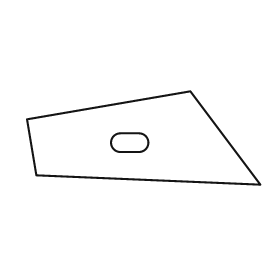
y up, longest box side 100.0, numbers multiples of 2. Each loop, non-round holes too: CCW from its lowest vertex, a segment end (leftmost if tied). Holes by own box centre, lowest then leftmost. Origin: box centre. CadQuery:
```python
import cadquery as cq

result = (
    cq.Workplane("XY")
    .moveTo(50.0, -20.0)
    .lineTo(20.0, 20.0)
    .lineTo(-50.0, 8.0)
    .lineTo(-46.0, -16.0)
    .close()
    .moveTo(-10.0, -6.0)
    .lineTo(-2.0, -6.0)
    .threePointArc((2.0, -2.0), (-2.0, 2.0))
    .lineTo(-10.0, 2.0)
    .threePointArc((-14.0, -2.0), (-10.0, -6.0))
    .close()
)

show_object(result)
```